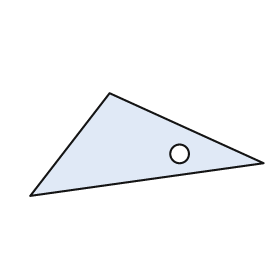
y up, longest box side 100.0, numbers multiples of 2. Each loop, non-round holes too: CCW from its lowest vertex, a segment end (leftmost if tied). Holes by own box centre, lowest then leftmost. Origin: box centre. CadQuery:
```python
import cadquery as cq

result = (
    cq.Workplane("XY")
    .moveTo(-50.0, -22.0)
    .lineTo(50.0, -8.0)
    .lineTo(-16.0, 22.0)
    .close()
    .moveTo(14.0, -4.0)
    .circle(4.0)
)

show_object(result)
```